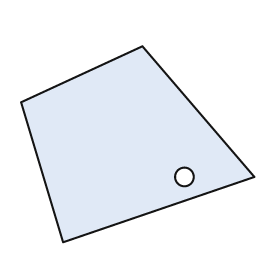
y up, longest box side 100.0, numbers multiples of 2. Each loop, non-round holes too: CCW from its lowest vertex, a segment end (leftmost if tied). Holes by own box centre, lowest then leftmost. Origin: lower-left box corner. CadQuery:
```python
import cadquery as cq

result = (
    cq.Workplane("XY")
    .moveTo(18.0, 0.0)
    .lineTo(100.0, 28.0)
    .lineTo(52.0, 84.0)
    .lineTo(0.0, 60.0)
    .close()
    .moveTo(70.0, 28.0)
    .circle(4.0)
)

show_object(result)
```